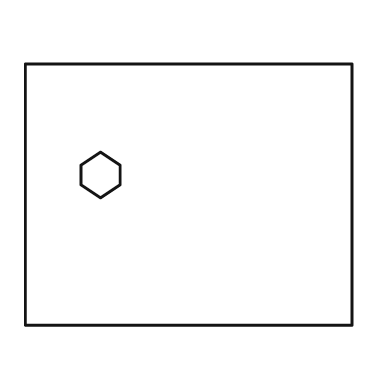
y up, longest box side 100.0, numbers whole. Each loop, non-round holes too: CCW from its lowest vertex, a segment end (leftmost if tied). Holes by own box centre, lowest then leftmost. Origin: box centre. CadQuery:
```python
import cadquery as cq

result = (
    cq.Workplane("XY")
    .moveTo(-50.0, -40.0)
    .lineTo(50.0, -40.0)
    .lineTo(50.0, 40.0)
    .lineTo(-50.0, 40.0)
    .close()
    .moveTo(-27.0, -1.0)
    .lineTo(-21.0, 3.0)
    .lineTo(-21.0, 9.0)
    .lineTo(-27.0, 13.0)
    .lineTo(-33.0, 9.0)
    .lineTo(-33.0, 3.0)
    .close()
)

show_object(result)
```